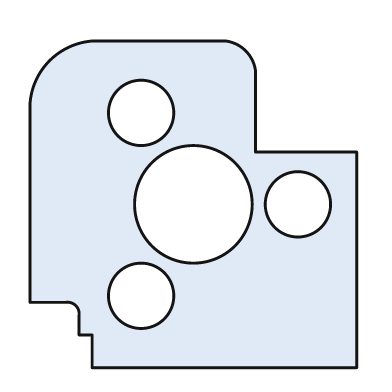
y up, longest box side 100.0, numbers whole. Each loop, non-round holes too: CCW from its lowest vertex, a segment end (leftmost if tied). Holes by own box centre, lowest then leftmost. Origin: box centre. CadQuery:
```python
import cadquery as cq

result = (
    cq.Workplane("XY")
    .moveTo(-31.0, -50.0)
    .lineTo(50.0, -50.0)
    .lineTo(50.0, 16.0)
    .lineTo(19.0, 16.0)
    .lineTo(19.0, 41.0)
    .threePointArc((16.0, 47.0), (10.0, 50.0))
    .lineTo(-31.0, 50.0)
    .threePointArc((-44.0, 44.0), (-50.0, 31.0))
    .lineTo(-50.0, -30.0)
    .lineTo(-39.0, -30.0)
    .threePointArc((-36.0, -31.0), (-35.0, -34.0))
    .lineTo(-35.0, -40.0)
    .lineTo(-31.0, -40.0)
    .close()
    .moveTo(-16.0, -28.0)
    .circle(10.0)
    .moveTo(0.0, 0.0)
    .circle(18.0)
    .moveTo(32.0, 0.0)
    .circle(10.0)
    .moveTo(-16.0, 28.0)
    .circle(10.0)
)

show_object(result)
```